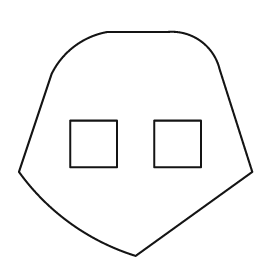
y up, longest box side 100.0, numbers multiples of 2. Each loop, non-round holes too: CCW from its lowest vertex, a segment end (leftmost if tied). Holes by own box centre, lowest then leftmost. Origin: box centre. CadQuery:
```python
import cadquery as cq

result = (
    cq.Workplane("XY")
    .moveTo(0.0, -48.0)
    .lineTo(50.0, -12.0)
    .lineTo(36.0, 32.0)
    .threePointArc((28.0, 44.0), (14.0, 48.0))
    .lineTo(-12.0, 48.0)
    .threePointArc((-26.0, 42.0), (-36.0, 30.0))
    .lineTo(-50.0, -12.0)
    .threePointArc((-28.0, -34.0), (0.0, -48.0))
    .close()
    .moveTo(-28.0, -10.0)
    .lineTo(-8.0, -10.0)
    .lineTo(-8.0, 10.0)
    .lineTo(-28.0, 10.0)
    .close()
    .moveTo(8.0, -10.0)
    .lineTo(28.0, -10.0)
    .lineTo(28.0, 10.0)
    .lineTo(8.0, 10.0)
    .close()
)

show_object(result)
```